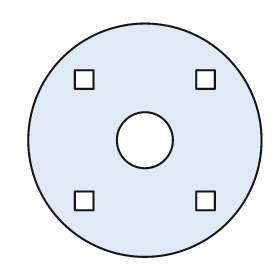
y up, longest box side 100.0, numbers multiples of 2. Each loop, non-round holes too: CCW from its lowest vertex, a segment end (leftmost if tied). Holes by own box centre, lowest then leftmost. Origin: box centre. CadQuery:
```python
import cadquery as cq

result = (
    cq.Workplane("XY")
    .moveTo(0.0, 0.0)
    .circle(50.0)
    .moveTo(-30.0, -30.0)
    .lineTo(-22.0, -30.0)
    .lineTo(-22.0, -22.0)
    .lineTo(-30.0, -22.0)
    .close()
    .moveTo(22.0, -30.0)
    .lineTo(30.0, -30.0)
    .lineTo(30.0, -22.0)
    .lineTo(22.0, -22.0)
    .close()
    .moveTo(0.0, 0.0)
    .circle(12.0)
    .moveTo(-30.0, 22.0)
    .lineTo(-22.0, 22.0)
    .lineTo(-22.0, 30.0)
    .lineTo(-30.0, 30.0)
    .close()
    .moveTo(22.0, 22.0)
    .lineTo(30.0, 22.0)
    .lineTo(30.0, 30.0)
    .lineTo(22.0, 30.0)
    .close()
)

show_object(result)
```